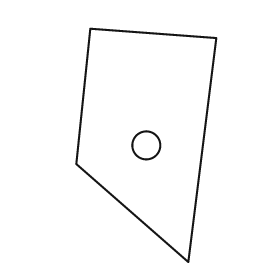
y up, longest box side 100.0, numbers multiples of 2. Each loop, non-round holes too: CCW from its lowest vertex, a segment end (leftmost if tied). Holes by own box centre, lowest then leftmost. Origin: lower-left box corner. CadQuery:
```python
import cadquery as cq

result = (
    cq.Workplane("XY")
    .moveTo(48.0, 0.0)
    .lineTo(60.0, 96.0)
    .lineTo(6.0, 100.0)
    .lineTo(0.0, 42.0)
    .close()
    .moveTo(30.0, 50.0)
    .circle(6.0)
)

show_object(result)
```